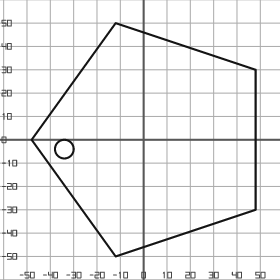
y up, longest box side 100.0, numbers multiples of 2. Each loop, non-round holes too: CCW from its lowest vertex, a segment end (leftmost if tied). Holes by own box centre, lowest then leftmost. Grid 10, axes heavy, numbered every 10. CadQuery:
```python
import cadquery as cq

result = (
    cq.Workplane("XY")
    .moveTo(-12.0, -50.0)
    .lineTo(48.0, -30.0)
    .lineTo(48.0, 30.0)
    .lineTo(-12.0, 50.0)
    .lineTo(-48.0, 0.0)
    .close()
    .moveTo(-34.0, -4.0)
    .circle(4.0)
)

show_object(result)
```